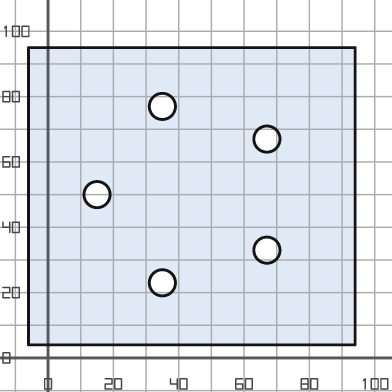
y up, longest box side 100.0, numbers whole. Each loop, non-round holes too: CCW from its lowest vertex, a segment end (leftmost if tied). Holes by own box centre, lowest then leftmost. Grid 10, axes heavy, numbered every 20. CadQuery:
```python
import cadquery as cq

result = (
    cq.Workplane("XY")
    .moveTo(-6.0, 4.0)
    .lineTo(94.0, 4.0)
    .lineTo(94.0, 95.0)
    .lineTo(-6.0, 95.0)
    .close()
    .moveTo(35.0, 23.0)
    .circle(4.0)
    .moveTo(67.0, 33.0)
    .circle(4.0)
    .moveTo(15.0, 50.0)
    .circle(4.0)
    .moveTo(67.0, 67.0)
    .circle(4.0)
    .moveTo(35.0, 77.0)
    .circle(4.0)
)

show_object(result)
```